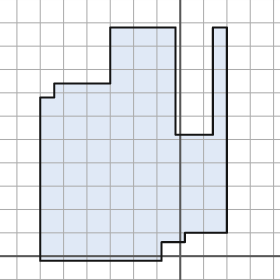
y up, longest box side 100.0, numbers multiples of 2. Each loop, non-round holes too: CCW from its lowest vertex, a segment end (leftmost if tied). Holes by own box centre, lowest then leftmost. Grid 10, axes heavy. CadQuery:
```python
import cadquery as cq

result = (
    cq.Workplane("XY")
    .moveTo(-60.0, -2.0)
    .lineTo(-8.0, -2.0)
    .lineTo(-8.0, 6.0)
    .lineTo(2.0, 6.0)
    .lineTo(2.0, 10.0)
    .lineTo(20.0, 10.0)
    .lineTo(20.0, 98.0)
    .lineTo(14.0, 98.0)
    .lineTo(14.0, 52.0)
    .lineTo(-2.0, 52.0)
    .lineTo(-2.0, 98.0)
    .lineTo(-30.0, 98.0)
    .lineTo(-30.0, 74.0)
    .lineTo(-54.0, 74.0)
    .lineTo(-54.0, 68.0)
    .lineTo(-60.0, 68.0)
    .close()
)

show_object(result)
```